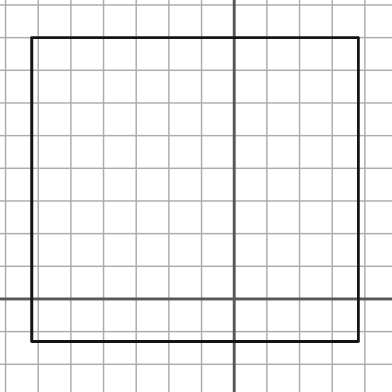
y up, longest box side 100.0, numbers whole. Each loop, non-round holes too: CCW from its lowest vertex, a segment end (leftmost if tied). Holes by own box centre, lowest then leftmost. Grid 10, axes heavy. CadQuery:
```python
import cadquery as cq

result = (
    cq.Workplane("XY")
    .moveTo(-62.0, -13.0)
    .lineTo(38.0, -13.0)
    .lineTo(38.0, 80.0)
    .lineTo(-62.0, 80.0)
    .close()
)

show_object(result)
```